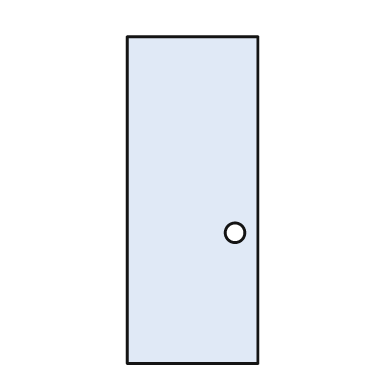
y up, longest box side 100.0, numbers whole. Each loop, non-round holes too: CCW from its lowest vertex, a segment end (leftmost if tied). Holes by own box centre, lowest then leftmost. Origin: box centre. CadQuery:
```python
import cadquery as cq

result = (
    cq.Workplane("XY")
    .moveTo(-20.0, -50.0)
    .lineTo(20.0, -50.0)
    .lineTo(20.0, 50.0)
    .lineTo(-20.0, 50.0)
    .close()
    .moveTo(13.0, -10.0)
    .circle(3.0)
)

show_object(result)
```